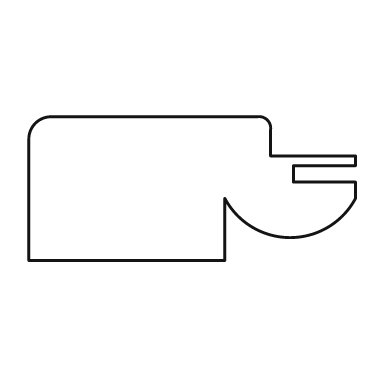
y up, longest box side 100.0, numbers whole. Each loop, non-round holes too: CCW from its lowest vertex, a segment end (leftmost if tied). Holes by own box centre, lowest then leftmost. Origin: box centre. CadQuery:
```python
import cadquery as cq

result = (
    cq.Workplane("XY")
    .moveTo(-50.0, -22.0)
    .lineTo(10.0, -22.0)
    .lineTo(10.0, -3.0)
    .threePointArc((30.0, -15.0), (50.0, -3.0))
    .lineTo(50.0, 2.0)
    .lineTo(31.0, 2.0)
    .lineTo(31.0, 7.0)
    .lineTo(50.0, 7.0)
    .lineTo(50.0, 10.0)
    .lineTo(24.0, 10.0)
    .lineTo(24.0, 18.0)
    .threePointArc((23.0, 21.0), (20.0, 22.0))
    .lineTo(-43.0, 22.0)
    .threePointArc((-48.0, 20.0), (-50.0, 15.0))
    .close()
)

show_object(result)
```